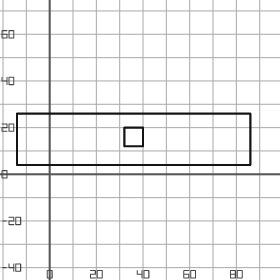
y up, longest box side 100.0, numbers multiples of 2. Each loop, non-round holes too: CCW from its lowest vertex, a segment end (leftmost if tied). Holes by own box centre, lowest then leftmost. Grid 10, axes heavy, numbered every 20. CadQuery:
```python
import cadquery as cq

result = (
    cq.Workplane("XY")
    .moveTo(-14.0, 4.0)
    .lineTo(86.0, 4.0)
    .lineTo(86.0, 26.0)
    .lineTo(-14.0, 26.0)
    .close()
    .moveTo(32.0, 12.0)
    .lineTo(40.0, 12.0)
    .lineTo(40.0, 20.0)
    .lineTo(32.0, 20.0)
    .close()
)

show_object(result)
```